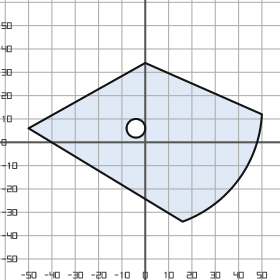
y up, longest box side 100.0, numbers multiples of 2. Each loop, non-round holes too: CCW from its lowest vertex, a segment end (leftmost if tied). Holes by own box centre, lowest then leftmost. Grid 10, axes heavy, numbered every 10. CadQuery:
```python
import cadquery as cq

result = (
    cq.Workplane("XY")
    .moveTo(16.0, -34.0)
    .threePointArc((40.0, -16.0), (50.0, 12.0))
    .lineTo(0.0, 34.0)
    .lineTo(-50.0, 6.0)
    .close()
    .moveTo(-4.0, 6.0)
    .circle(4.0)
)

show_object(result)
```